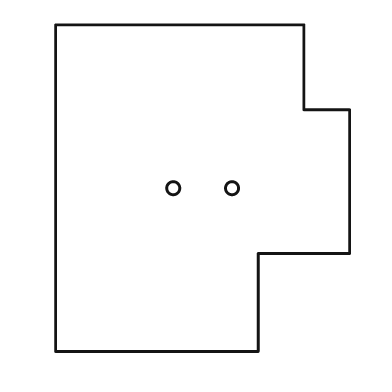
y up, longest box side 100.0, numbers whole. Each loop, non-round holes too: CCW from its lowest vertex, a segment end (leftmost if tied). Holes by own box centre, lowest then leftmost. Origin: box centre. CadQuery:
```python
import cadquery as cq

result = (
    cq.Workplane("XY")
    .moveTo(-45.0, -50.0)
    .lineTo(17.0, -50.0)
    .lineTo(17.0, -20.0)
    .lineTo(45.0, -20.0)
    .lineTo(45.0, 24.0)
    .lineTo(31.0, 24.0)
    .lineTo(31.0, 50.0)
    .lineTo(-45.0, 50.0)
    .close()
    .moveTo(-9.0, 0.0)
    .circle(2.0)
    .moveTo(9.0, 0.0)
    .circle(2.0)
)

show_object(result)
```